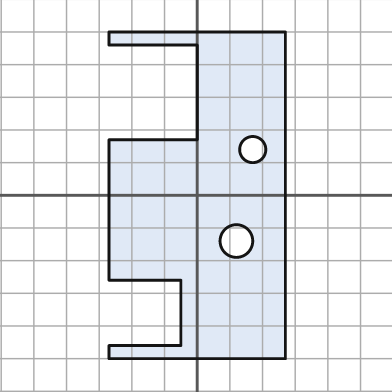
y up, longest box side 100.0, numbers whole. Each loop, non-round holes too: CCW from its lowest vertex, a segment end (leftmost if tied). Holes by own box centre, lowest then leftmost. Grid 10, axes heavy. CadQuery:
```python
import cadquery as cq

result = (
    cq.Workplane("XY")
    .moveTo(-27.0, -50.0)
    .lineTo(27.0, -50.0)
    .lineTo(27.0, 50.0)
    .lineTo(-27.0, 50.0)
    .lineTo(-27.0, 46.0)
    .lineTo(0.0, 46.0)
    .lineTo(0.0, 17.0)
    .lineTo(-27.0, 17.0)
    .lineTo(-27.0, -26.0)
    .lineTo(-5.0, -26.0)
    .lineTo(-5.0, -46.0)
    .lineTo(-27.0, -46.0)
    .close()
    .moveTo(12.0, -14.0)
    .circle(5.0)
    .moveTo(17.0, 14.0)
    .circle(4.0)
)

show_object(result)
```